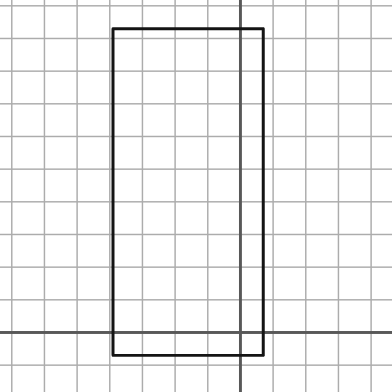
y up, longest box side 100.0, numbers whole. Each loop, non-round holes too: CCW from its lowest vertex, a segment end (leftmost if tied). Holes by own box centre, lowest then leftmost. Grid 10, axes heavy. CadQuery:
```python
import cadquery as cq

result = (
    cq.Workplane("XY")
    .moveTo(-39.0, -7.0)
    .lineTo(7.0, -7.0)
    .lineTo(7.0, 93.0)
    .lineTo(-39.0, 93.0)
    .close()
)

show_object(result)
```